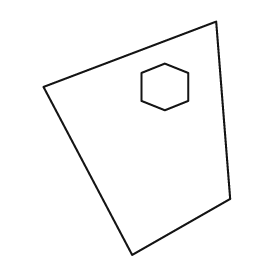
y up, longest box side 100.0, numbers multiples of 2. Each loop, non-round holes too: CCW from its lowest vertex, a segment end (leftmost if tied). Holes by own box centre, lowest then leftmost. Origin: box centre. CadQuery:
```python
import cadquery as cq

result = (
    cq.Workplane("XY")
    .moveTo(-2.0, -50.0)
    .lineTo(40.0, -26.0)
    .lineTo(34.0, 50.0)
    .lineTo(-40.0, 22.0)
    .close()
    .moveTo(12.0, 12.0)
    .lineTo(22.0, 16.0)
    .lineTo(22.0, 28.0)
    .lineTo(12.0, 32.0)
    .lineTo(2.0, 28.0)
    .lineTo(2.0, 16.0)
    .close()
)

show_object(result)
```